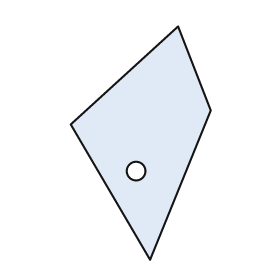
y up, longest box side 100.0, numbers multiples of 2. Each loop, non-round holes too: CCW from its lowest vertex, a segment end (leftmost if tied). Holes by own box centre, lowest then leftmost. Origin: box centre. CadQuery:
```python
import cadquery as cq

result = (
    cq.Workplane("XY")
    .moveTo(4.0, -50.0)
    .lineTo(30.0, 14.0)
    .lineTo(16.0, 50.0)
    .lineTo(-30.0, 8.0)
    .close()
    .moveTo(-2.0, -12.0)
    .circle(4.0)
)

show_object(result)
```